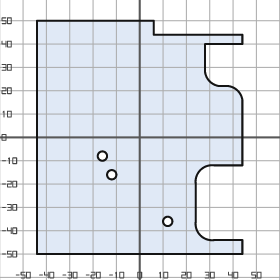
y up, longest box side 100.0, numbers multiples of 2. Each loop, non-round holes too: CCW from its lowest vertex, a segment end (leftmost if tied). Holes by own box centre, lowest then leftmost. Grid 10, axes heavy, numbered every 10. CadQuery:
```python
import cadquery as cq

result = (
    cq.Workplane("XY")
    .moveTo(-44.0, -50.0)
    .lineTo(44.0, -50.0)
    .lineTo(44.0, -44.0)
    .lineTo(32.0, -44.0)
    .threePointArc((26.0, -42.0), (24.0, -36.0))
    .lineTo(24.0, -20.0)
    .threePointArc((26.0, -14.0), (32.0, -12.0))
    .lineTo(44.0, -12.0)
    .lineTo(44.0, 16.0)
    .threePointArc((42.0, 20.0), (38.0, 22.0))
    .lineTo(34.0, 22.0)
    .threePointArc((30.0, 24.0), (28.0, 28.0))
    .lineTo(28.0, 40.0)
    .lineTo(44.0, 40.0)
    .lineTo(44.0, 44.0)
    .lineTo(6.0, 44.0)
    .lineTo(6.0, 50.0)
    .lineTo(-44.0, 50.0)
    .close()
    .moveTo(12.0, -36.0)
    .circle(2.0)
    .moveTo(-12.0, -16.0)
    .circle(2.0)
    .moveTo(-16.0, -8.0)
    .circle(2.0)
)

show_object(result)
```